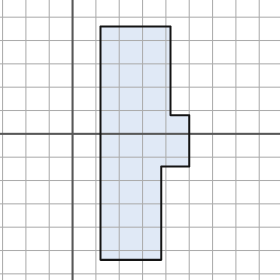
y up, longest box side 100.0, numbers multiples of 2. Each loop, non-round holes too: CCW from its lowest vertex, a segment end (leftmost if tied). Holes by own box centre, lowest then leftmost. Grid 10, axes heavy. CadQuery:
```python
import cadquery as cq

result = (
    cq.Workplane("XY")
    .moveTo(12.0, -54.0)
    .lineTo(38.0, -54.0)
    .lineTo(38.0, -14.0)
    .lineTo(50.0, -14.0)
    .lineTo(50.0, 8.0)
    .lineTo(42.0, 8.0)
    .lineTo(42.0, 46.0)
    .lineTo(12.0, 46.0)
    .close()
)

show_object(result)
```